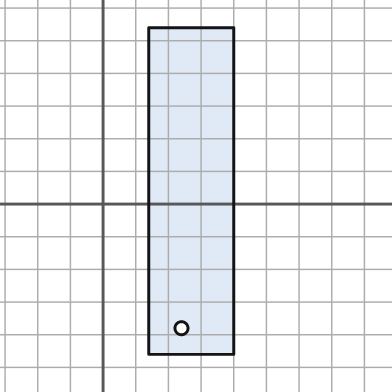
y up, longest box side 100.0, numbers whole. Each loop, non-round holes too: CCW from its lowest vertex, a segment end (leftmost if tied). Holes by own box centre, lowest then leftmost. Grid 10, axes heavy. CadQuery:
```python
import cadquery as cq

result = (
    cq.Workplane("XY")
    .moveTo(14.0, -46.0)
    .lineTo(40.0, -46.0)
    .lineTo(40.0, 54.0)
    .lineTo(14.0, 54.0)
    .close()
    .moveTo(24.0, -38.0)
    .circle(2.0)
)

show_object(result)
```